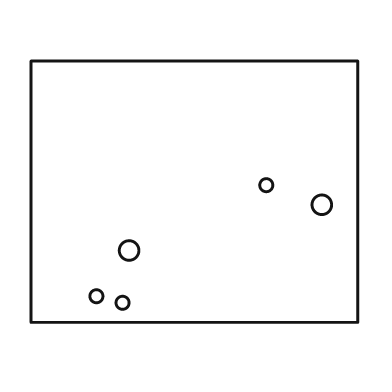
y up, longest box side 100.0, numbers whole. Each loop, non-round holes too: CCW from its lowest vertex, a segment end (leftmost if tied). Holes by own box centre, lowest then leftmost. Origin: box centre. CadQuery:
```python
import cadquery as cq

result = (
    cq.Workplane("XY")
    .moveTo(-50.0, -40.0)
    .lineTo(50.0, -40.0)
    .lineTo(50.0, 40.0)
    .lineTo(-50.0, 40.0)
    .close()
    .moveTo(-22.0, -34.0)
    .circle(2.0)
    .moveTo(-30.0, -32.0)
    .circle(2.0)
    .moveTo(-20.0, -18.0)
    .circle(3.0)
    .moveTo(39.0, -4.0)
    .circle(3.0)
    .moveTo(22.0, 2.0)
    .circle(2.0)
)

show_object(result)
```